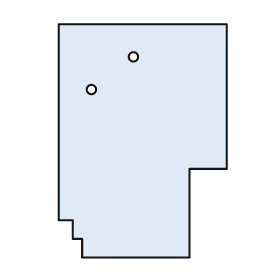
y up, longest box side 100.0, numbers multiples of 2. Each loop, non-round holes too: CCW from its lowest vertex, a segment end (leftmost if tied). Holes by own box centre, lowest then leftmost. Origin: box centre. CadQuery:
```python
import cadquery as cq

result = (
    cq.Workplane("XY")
    .moveTo(-26.0, -50.0)
    .lineTo(20.0, -50.0)
    .lineTo(20.0, -12.0)
    .lineTo(36.0, -12.0)
    .lineTo(36.0, 50.0)
    .lineTo(-36.0, 50.0)
    .lineTo(-36.0, -34.0)
    .lineTo(-30.0, -34.0)
    .lineTo(-30.0, -42.0)
    .lineTo(-26.0, -42.0)
    .close()
    .moveTo(-22.0, 22.0)
    .circle(2.0)
    .moveTo(-4.0, 36.0)
    .circle(2.0)
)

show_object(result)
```